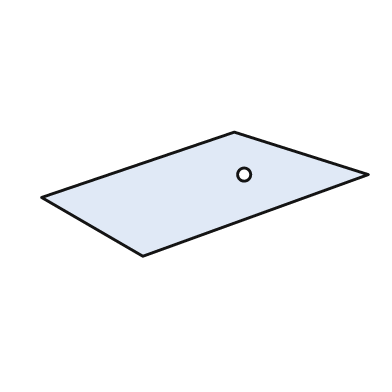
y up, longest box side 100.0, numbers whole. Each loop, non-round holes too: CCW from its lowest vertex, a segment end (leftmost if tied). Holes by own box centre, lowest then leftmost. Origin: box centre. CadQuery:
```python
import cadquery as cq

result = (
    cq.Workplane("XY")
    .moveTo(-19.0, -19.0)
    .lineTo(50.0, 6.0)
    .lineTo(9.0, 19.0)
    .lineTo(-50.0, -1.0)
    .close()
    .moveTo(12.0, 6.0)
    .circle(2.0)
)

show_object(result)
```